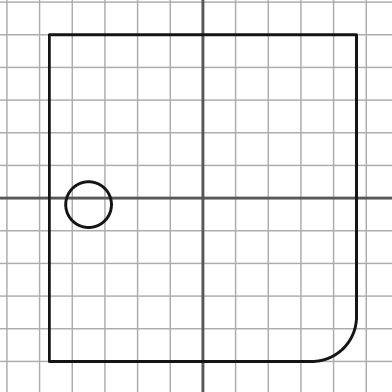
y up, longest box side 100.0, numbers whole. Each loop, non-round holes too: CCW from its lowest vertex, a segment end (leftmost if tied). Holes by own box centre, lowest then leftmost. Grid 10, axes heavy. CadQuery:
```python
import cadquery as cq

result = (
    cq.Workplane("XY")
    .moveTo(-47.0, -50.0)
    .lineTo(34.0, -50.0)
    .threePointArc((43.0, -46.0), (47.0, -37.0))
    .lineTo(47.0, 50.0)
    .lineTo(-47.0, 50.0)
    .close()
    .moveTo(-35.0, -2.0)
    .circle(7.0)
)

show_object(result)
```